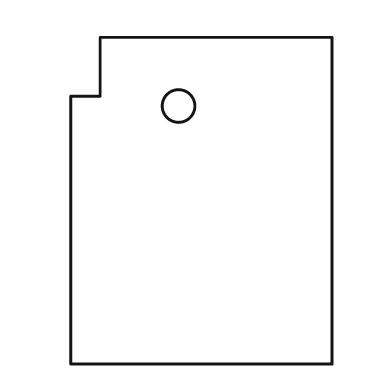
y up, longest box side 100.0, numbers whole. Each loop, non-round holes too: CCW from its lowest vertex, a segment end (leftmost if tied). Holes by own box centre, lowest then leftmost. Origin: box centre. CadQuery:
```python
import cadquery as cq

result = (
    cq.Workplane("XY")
    .moveTo(-40.0, -50.0)
    .lineTo(40.0, -50.0)
    .lineTo(40.0, 50.0)
    .lineTo(-31.0, 50.0)
    .lineTo(-31.0, 32.0)
    .lineTo(-40.0, 32.0)
    .close()
    .moveTo(-7.0, 29.0)
    .circle(5.0)
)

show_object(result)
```